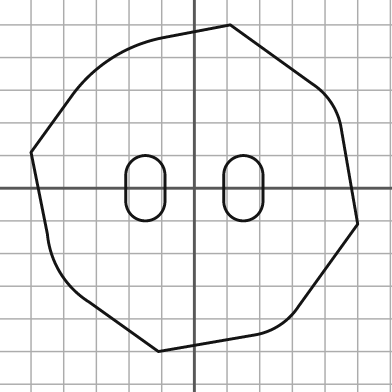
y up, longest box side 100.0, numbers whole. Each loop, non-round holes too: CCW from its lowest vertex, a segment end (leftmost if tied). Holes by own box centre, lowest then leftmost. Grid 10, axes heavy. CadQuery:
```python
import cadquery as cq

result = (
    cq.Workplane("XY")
    .moveTo(-11.0, -50.0)
    .lineTo(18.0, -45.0)
    .threePointArc((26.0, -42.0), (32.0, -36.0))
    .lineTo(50.0, -11.0)
    .lineTo(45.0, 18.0)
    .threePointArc((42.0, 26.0), (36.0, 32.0))
    .lineTo(11.0, 50.0)
    .lineTo(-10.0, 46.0)
    .threePointArc((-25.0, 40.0), (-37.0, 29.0))
    .lineTo(-50.0, 11.0)
    .lineTo(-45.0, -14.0)
    .threePointArc((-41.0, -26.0), (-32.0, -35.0))
    .close()
    .moveTo(-21.0, -4.0)
    .threePointArc((-15.0, -10.0), (-9.0, -4.0))
    .lineTo(-9.0, 4.0)
    .threePointArc((-15.0, 10.0), (-21.0, 4.0))
    .close()
    .moveTo(9.0, -4.0)
    .threePointArc((15.0, -10.0), (21.0, -4.0))
    .lineTo(21.0, 4.0)
    .threePointArc((15.0, 10.0), (9.0, 4.0))
    .close()
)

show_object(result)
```